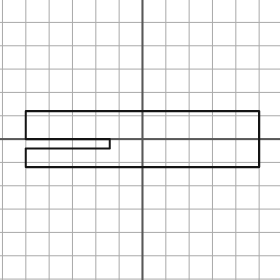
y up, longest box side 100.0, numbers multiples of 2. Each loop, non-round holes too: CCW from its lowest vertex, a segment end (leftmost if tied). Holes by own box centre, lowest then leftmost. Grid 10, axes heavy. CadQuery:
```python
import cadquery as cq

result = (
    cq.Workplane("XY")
    .moveTo(-50.0, -12.0)
    .lineTo(50.0, -12.0)
    .lineTo(50.0, 12.0)
    .lineTo(-50.0, 12.0)
    .lineTo(-50.0, 0.0)
    .lineTo(-14.0, 0.0)
    .lineTo(-14.0, -4.0)
    .lineTo(-50.0, -4.0)
    .close()
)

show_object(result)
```